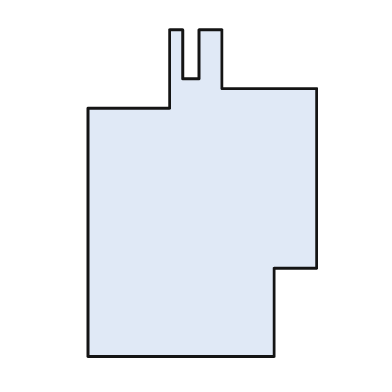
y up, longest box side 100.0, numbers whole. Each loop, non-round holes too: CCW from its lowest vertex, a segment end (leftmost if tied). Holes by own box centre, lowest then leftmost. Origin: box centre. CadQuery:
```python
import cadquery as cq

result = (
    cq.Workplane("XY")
    .moveTo(-35.0, -50.0)
    .lineTo(22.0, -50.0)
    .lineTo(22.0, -23.0)
    .lineTo(35.0, -23.0)
    .lineTo(35.0, 32.0)
    .lineTo(6.0, 32.0)
    .lineTo(6.0, 50.0)
    .lineTo(-1.0, 50.0)
    .lineTo(-1.0, 35.0)
    .lineTo(-6.0, 35.0)
    .lineTo(-6.0, 50.0)
    .lineTo(-10.0, 50.0)
    .lineTo(-10.0, 26.0)
    .lineTo(-35.0, 26.0)
    .close()
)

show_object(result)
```